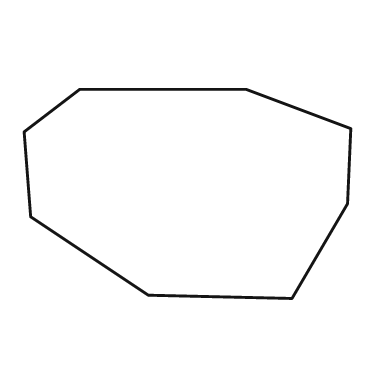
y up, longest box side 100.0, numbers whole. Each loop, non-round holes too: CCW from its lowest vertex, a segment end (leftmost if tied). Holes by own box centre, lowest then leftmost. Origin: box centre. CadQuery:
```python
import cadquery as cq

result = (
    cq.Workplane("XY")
    .moveTo(32.0, -32.0)
    .lineTo(49.0, -3.0)
    .lineTo(50.0, 20.0)
    .lineTo(18.0, 32.0)
    .lineTo(-33.0, 32.0)
    .lineTo(-50.0, 19.0)
    .lineTo(-48.0, -7.0)
    .lineTo(-12.0, -31.0)
    .close()
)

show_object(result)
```